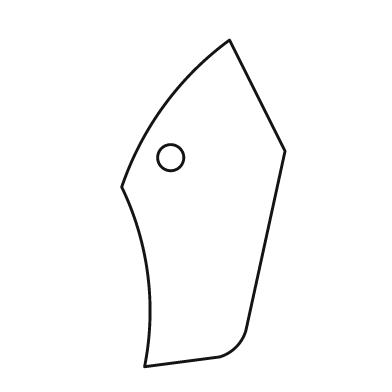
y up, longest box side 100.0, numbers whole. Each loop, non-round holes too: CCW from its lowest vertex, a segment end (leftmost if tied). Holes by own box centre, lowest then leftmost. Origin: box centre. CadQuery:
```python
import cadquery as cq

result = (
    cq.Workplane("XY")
    .moveTo(-18.0, -50.0)
    .lineTo(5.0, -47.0)
    .threePointArc((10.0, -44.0), (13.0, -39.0))
    .lineTo(25.0, 16.0)
    .lineTo(8.0, 50.0)
    .threePointArc((-12.0, 30.0), (-25.0, 5.0))
    .threePointArc((-17.0, -22.0), (-18.0, -50.0))
    .close()
    .moveTo(-10.0, 14.0)
    .circle(4.0)
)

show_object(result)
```